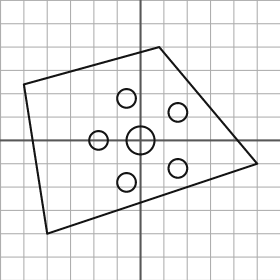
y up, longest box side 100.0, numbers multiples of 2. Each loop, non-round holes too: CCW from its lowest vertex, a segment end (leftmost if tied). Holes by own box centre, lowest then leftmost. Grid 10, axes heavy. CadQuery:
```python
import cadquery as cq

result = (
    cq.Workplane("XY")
    .moveTo(-40.0, -40.0)
    .lineTo(50.0, -10.0)
    .lineTo(8.0, 40.0)
    .lineTo(-50.0, 24.0)
    .close()
    .moveTo(-6.0, -18.0)
    .circle(4.0)
    .moveTo(16.0, -12.0)
    .circle(4.0)
    .moveTo(-18.0, 0.0)
    .circle(4.0)
    .moveTo(0.0, 0.0)
    .circle(6.0)
    .moveTo(16.0, 12.0)
    .circle(4.0)
    .moveTo(-6.0, 18.0)
    .circle(4.0)
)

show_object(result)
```